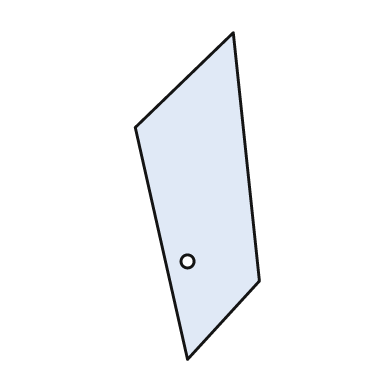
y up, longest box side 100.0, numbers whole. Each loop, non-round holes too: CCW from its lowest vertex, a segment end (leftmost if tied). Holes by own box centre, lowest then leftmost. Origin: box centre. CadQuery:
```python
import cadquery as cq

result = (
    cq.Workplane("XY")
    .moveTo(-3.0, -50.0)
    .lineTo(19.0, -26.0)
    .lineTo(11.0, 50.0)
    .lineTo(-19.0, 21.0)
    .close()
    .moveTo(-3.0, -20.0)
    .circle(2.0)
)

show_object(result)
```